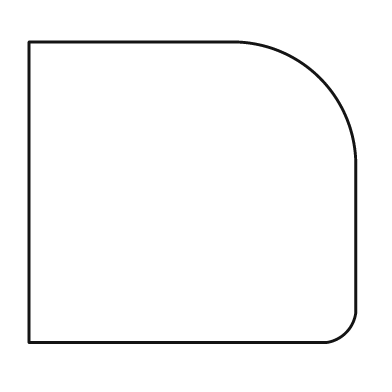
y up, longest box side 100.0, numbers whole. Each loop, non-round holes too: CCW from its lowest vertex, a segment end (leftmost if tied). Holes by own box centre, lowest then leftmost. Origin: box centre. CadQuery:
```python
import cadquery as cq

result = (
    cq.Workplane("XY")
    .moveTo(-50.0, -46.0)
    .lineTo(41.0, -46.0)
    .threePointArc((47.0, -43.0), (50.0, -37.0))
    .lineTo(50.0, 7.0)
    .threePointArc((39.0, 35.0), (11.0, 46.0))
    .lineTo(-50.0, 46.0)
    .close()
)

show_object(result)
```